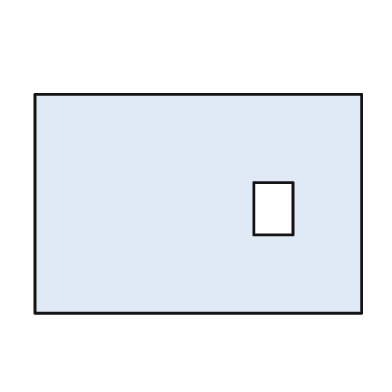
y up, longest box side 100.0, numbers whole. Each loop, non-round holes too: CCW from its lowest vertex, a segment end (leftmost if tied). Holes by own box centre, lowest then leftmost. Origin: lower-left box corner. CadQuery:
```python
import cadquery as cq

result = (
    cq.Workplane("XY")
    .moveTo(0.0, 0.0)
    .lineTo(100.0, 0.0)
    .lineTo(100.0, 67.0)
    .lineTo(0.0, 67.0)
    .close()
    .moveTo(67.0, 24.0)
    .lineTo(79.0, 24.0)
    .lineTo(79.0, 40.0)
    .lineTo(67.0, 40.0)
    .close()
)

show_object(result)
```